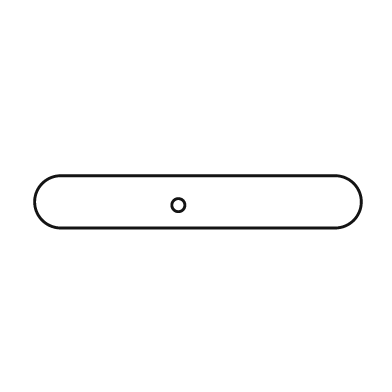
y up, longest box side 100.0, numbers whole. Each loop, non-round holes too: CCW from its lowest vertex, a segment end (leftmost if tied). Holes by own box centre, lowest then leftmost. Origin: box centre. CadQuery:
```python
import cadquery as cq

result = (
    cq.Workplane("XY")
    .moveTo(-42.0, -8.0)
    .lineTo(42.0, -8.0)
    .threePointArc((50.0, 0.0), (42.0, 8.0))
    .lineTo(-42.0, 8.0)
    .threePointArc((-50.0, 0.0), (-42.0, -8.0))
    .close()
    .moveTo(-6.0, -1.0)
    .circle(2.0)
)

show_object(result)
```